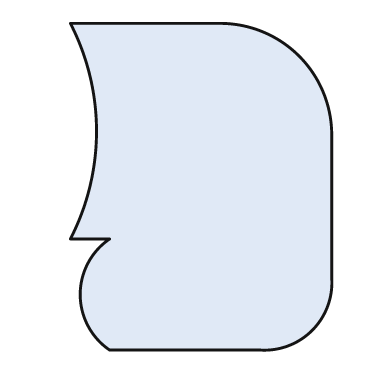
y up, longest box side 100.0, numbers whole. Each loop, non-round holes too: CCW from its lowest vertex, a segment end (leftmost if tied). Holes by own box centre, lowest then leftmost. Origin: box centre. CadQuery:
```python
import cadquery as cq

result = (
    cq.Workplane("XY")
    .moveTo(-28.0, -50.0)
    .lineTo(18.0, -50.0)
    .threePointArc((34.0, -44.0), (40.0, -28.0))
    .lineTo(40.0, 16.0)
    .threePointArc((30.0, 40.0), (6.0, 50.0))
    .lineTo(-40.0, 50.0)
    .threePointArc((-32.0, 17.0), (-40.0, -16.0))
    .lineTo(-28.0, -16.0)
    .threePointArc((-37.0, -33.0), (-28.0, -50.0))
    .close()
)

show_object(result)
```